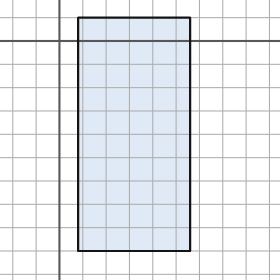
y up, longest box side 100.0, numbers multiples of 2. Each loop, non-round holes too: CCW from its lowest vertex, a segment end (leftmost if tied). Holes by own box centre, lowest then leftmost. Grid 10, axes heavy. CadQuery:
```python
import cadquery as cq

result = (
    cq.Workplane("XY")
    .moveTo(8.0, -90.0)
    .lineTo(56.0, -90.0)
    .lineTo(56.0, 10.0)
    .lineTo(8.0, 10.0)
    .close()
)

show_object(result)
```